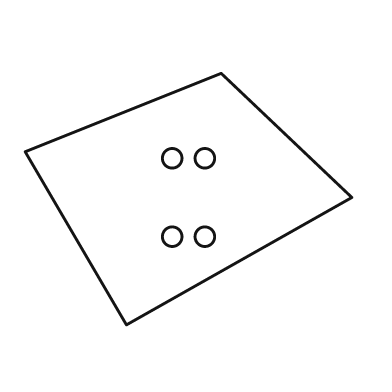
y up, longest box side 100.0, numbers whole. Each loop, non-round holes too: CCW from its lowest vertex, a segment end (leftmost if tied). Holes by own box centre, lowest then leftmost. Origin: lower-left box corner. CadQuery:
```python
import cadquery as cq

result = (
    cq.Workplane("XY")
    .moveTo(31.0, 0.0)
    .lineTo(100.0, 39.0)
    .lineTo(60.0, 77.0)
    .lineTo(0.0, 53.0)
    .close()
    .moveTo(45.0, 27.0)
    .circle(3.0)
    .moveTo(55.0, 27.0)
    .circle(3.0)
    .moveTo(45.0, 51.0)
    .circle(3.0)
    .moveTo(55.0, 51.0)
    .circle(3.0)
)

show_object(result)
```